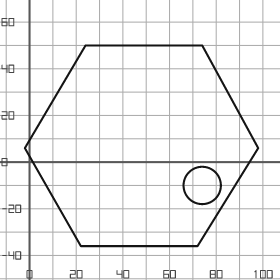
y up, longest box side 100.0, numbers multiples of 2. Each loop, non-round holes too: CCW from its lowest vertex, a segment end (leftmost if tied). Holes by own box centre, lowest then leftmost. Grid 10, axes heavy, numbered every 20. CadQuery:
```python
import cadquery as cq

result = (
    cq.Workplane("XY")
    .moveTo(22.0, -36.0)
    .lineTo(72.0, -36.0)
    .lineTo(98.0, 6.0)
    .lineTo(74.0, 50.0)
    .lineTo(24.0, 50.0)
    .lineTo(-2.0, 6.0)
    .close()
    .moveTo(74.0, -10.0)
    .circle(8.0)
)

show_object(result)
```